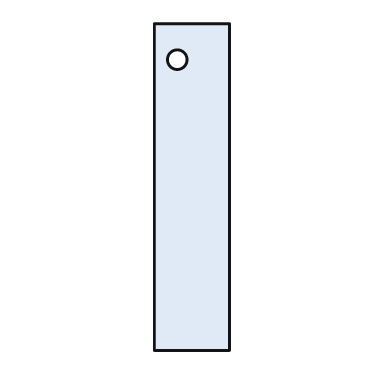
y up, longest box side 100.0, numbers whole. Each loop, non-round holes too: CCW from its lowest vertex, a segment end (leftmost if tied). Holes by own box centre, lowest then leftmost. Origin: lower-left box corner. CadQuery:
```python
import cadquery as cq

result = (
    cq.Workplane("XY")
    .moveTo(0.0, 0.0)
    .lineTo(23.0, 0.0)
    .lineTo(23.0, 100.0)
    .lineTo(0.0, 100.0)
    .close()
    .moveTo(7.0, 89.0)
    .circle(3.0)
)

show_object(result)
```